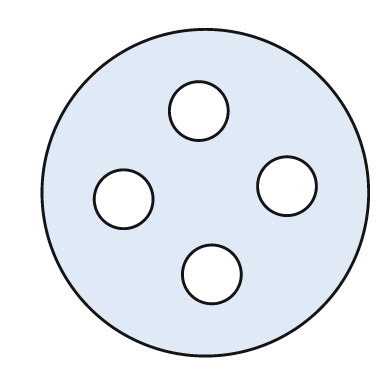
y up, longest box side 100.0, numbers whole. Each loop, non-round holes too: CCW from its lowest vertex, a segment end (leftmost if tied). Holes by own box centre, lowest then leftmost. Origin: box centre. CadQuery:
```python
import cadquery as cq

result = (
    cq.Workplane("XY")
    .moveTo(0.0, 0.0)
    .circle(50.0)
    .moveTo(2.0, -25.0)
    .circle(9.0)
    .moveTo(-25.0, -2.0)
    .circle(9.0)
    .moveTo(25.0, 2.0)
    .circle(9.0)
    .moveTo(-2.0, 25.0)
    .circle(9.0)
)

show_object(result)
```